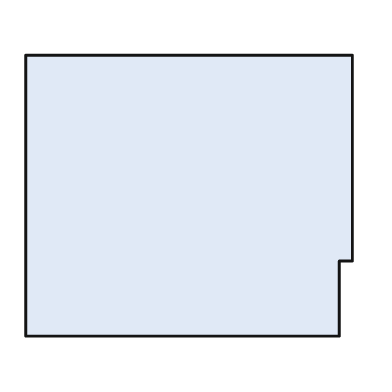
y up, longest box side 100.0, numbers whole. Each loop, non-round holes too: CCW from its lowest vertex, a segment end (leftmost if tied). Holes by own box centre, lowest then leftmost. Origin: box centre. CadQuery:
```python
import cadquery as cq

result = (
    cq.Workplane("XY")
    .moveTo(-50.0, -43.0)
    .lineTo(46.0, -43.0)
    .lineTo(46.0, -20.0)
    .lineTo(50.0, -20.0)
    .lineTo(50.0, 43.0)
    .lineTo(-50.0, 43.0)
    .close()
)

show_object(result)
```